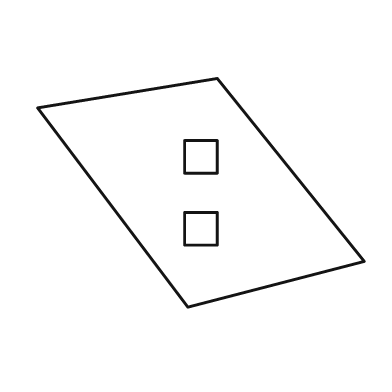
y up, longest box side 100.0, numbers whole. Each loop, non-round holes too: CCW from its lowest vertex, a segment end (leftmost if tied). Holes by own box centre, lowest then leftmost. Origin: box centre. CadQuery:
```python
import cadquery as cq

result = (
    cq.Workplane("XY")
    .moveTo(-4.0, -35.0)
    .lineTo(50.0, -21.0)
    .lineTo(5.0, 35.0)
    .lineTo(-50.0, 26.0)
    .close()
    .moveTo(-5.0, -16.0)
    .lineTo(5.0, -16.0)
    .lineTo(5.0, -6.0)
    .lineTo(-5.0, -6.0)
    .close()
    .moveTo(-5.0, 6.0)
    .lineTo(5.0, 6.0)
    .lineTo(5.0, 16.0)
    .lineTo(-5.0, 16.0)
    .close()
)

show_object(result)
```